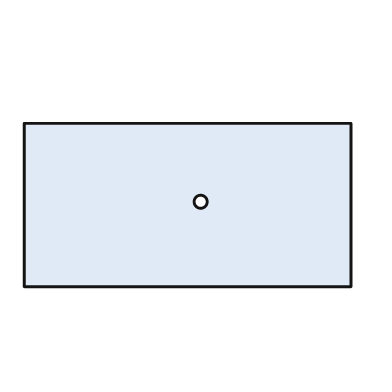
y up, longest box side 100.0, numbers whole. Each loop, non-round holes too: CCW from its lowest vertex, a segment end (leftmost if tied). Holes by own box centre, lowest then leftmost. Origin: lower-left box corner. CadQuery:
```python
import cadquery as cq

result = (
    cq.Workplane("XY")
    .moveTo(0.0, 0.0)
    .lineTo(100.0, 0.0)
    .lineTo(100.0, 50.0)
    .lineTo(0.0, 50.0)
    .close()
    .moveTo(54.0, 26.0)
    .circle(2.0)
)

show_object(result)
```